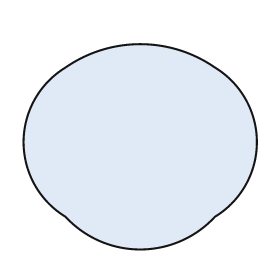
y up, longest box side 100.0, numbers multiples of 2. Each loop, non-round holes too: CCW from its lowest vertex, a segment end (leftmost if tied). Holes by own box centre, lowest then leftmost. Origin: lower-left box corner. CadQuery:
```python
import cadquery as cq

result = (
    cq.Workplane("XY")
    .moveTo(18.0, 14.0)
    .threePointArc((50.0, 0.0), (82.0, 14.0))
    .threePointArc((100.0, 46.0), (82.0, 78.0))
    .threePointArc((50.0, 88.0), (18.0, 78.0))
    .threePointArc((0.0, 46.0), (18.0, 14.0))
    .close()
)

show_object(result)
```